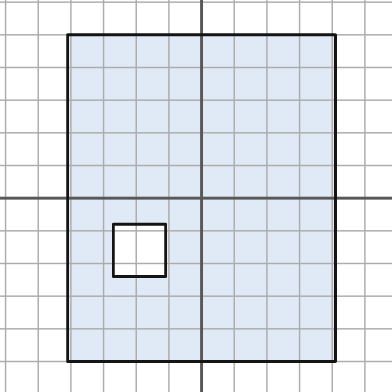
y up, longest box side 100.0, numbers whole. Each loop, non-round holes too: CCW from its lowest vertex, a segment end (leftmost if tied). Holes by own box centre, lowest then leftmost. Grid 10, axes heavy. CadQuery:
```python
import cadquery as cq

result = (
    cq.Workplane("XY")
    .moveTo(-41.0, -50.0)
    .lineTo(41.0, -50.0)
    .lineTo(41.0, 50.0)
    .lineTo(-41.0, 50.0)
    .close()
    .moveTo(-27.0, -24.0)
    .lineTo(-11.0, -24.0)
    .lineTo(-11.0, -8.0)
    .lineTo(-27.0, -8.0)
    .close()
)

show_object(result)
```